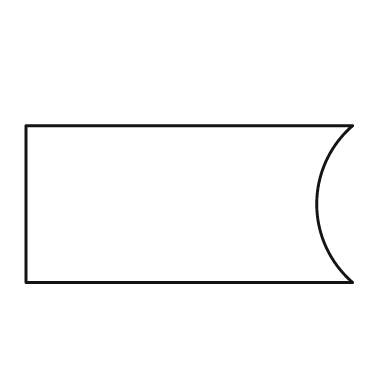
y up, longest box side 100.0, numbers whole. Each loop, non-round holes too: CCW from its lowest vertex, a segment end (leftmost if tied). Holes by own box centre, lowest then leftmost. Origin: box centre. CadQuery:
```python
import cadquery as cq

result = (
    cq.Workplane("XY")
    .moveTo(-50.0, -24.0)
    .lineTo(50.0, -24.0)
    .threePointArc((39.0, 0.0), (50.0, 24.0))
    .lineTo(-50.0, 24.0)
    .close()
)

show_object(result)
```